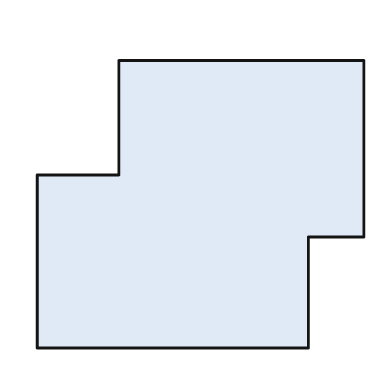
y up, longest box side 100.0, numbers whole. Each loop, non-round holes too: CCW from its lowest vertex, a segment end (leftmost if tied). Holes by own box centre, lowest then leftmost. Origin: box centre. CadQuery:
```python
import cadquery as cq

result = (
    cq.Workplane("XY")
    .moveTo(-50.0, -44.0)
    .lineTo(33.0, -44.0)
    .lineTo(33.0, -10.0)
    .lineTo(50.0, -10.0)
    .lineTo(50.0, 44.0)
    .lineTo(-25.0, 44.0)
    .lineTo(-25.0, 9.0)
    .lineTo(-50.0, 9.0)
    .close()
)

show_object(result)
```